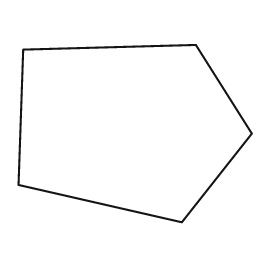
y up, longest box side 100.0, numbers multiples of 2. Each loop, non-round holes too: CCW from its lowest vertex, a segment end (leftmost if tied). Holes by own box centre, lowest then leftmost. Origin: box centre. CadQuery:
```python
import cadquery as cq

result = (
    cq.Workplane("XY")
    .moveTo(20.0, -38.0)
    .lineTo(50.0, 0.0)
    .lineTo(26.0, 38.0)
    .lineTo(-48.0, 36.0)
    .lineTo(-50.0, -22.0)
    .close()
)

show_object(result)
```